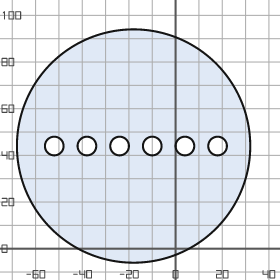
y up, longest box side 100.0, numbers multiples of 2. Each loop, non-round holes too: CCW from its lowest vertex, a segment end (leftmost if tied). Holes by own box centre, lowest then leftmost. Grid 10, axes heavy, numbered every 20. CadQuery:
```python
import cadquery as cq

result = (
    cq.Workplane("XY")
    .moveTo(-18.0, 44.0)
    .circle(50.0)
    .moveTo(-52.0, 44.0)
    .circle(4.0)
    .moveTo(-38.0, 44.0)
    .circle(4.0)
    .moveTo(-24.0, 44.0)
    .circle(4.0)
    .moveTo(-10.0, 44.0)
    .circle(4.0)
    .moveTo(4.0, 44.0)
    .circle(4.0)
    .moveTo(18.0, 44.0)
    .circle(4.0)
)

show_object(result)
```